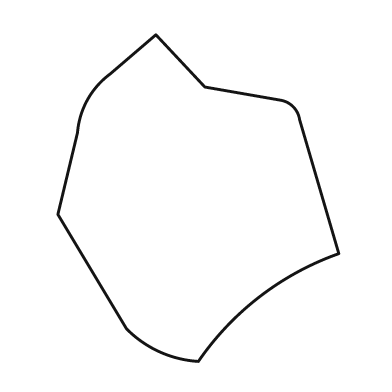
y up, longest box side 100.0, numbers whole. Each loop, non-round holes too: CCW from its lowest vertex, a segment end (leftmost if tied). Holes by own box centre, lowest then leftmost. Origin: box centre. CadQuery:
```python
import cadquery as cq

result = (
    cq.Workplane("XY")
    .moveTo(0.0, -50.0)
    .threePointArc((19.0, -30.0), (43.0, -17.0))
    .lineTo(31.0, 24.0)
    .threePointArc((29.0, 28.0), (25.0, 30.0))
    .lineTo(2.0, 34.0)
    .lineTo(-13.0, 50.0)
    .lineTo(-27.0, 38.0)
    .threePointArc((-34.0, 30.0), (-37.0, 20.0))
    .lineTo(-43.0, -5.0)
    .lineTo(-22.0, -40.0)
    .threePointArc((-12.0, -47.0), (0.0, -50.0))
    .close()
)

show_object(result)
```